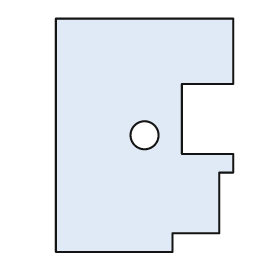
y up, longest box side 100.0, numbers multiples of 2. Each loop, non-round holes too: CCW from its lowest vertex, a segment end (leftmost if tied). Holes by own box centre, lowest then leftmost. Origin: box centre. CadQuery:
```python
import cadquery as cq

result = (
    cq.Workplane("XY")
    .moveTo(-38.0, -50.0)
    .lineTo(12.0, -50.0)
    .lineTo(12.0, -42.0)
    .lineTo(32.0, -42.0)
    .lineTo(32.0, -16.0)
    .lineTo(38.0, -16.0)
    .lineTo(38.0, -8.0)
    .lineTo(16.0, -8.0)
    .lineTo(16.0, 22.0)
    .lineTo(38.0, 22.0)
    .lineTo(38.0, 50.0)
    .lineTo(-38.0, 50.0)
    .close()
    .moveTo(0.0, 0.0)
    .circle(6.0)
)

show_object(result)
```